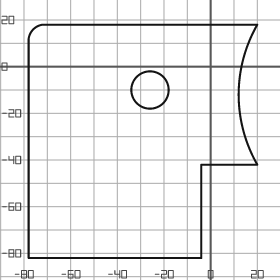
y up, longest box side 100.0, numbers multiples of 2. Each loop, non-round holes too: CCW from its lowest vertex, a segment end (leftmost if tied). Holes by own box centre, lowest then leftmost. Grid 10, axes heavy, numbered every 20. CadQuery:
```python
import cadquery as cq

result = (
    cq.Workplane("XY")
    .moveTo(-78.0, -82.0)
    .lineTo(-4.0, -82.0)
    .lineTo(-4.0, -42.0)
    .lineTo(20.0, -42.0)
    .threePointArc((12.0, -12.0), (20.0, 18.0))
    .lineTo(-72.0, 18.0)
    .threePointArc((-76.0, 16.0), (-78.0, 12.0))
    .close()
    .moveTo(-26.0, -10.0)
    .circle(8.0)
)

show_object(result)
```